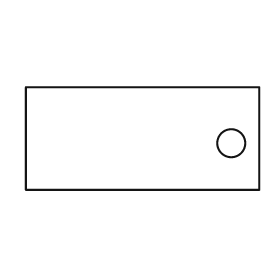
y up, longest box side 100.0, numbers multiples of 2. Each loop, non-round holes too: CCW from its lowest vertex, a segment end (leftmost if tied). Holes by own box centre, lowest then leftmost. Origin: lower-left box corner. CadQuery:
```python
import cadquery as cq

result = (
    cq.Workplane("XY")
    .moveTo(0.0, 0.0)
    .lineTo(100.0, 0.0)
    .lineTo(100.0, 44.0)
    .lineTo(0.0, 44.0)
    .close()
    .moveTo(88.0, 20.0)
    .circle(6.0)
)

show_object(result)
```